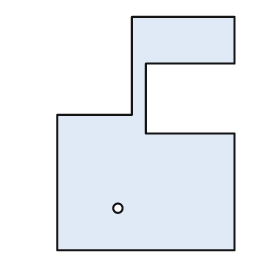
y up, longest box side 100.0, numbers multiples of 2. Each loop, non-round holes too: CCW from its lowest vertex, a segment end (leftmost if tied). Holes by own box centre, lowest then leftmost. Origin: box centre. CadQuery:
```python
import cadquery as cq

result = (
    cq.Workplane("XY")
    .moveTo(-38.0, -50.0)
    .lineTo(38.0, -50.0)
    .lineTo(38.0, 0.0)
    .lineTo(0.0, 0.0)
    .lineTo(0.0, 30.0)
    .lineTo(38.0, 30.0)
    .lineTo(38.0, 50.0)
    .lineTo(-6.0, 50.0)
    .lineTo(-6.0, 8.0)
    .lineTo(-38.0, 8.0)
    .close()
    .moveTo(-12.0, -32.0)
    .circle(2.0)
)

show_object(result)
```